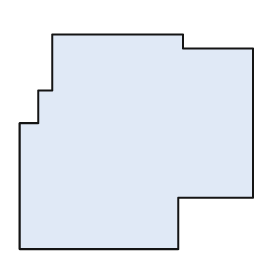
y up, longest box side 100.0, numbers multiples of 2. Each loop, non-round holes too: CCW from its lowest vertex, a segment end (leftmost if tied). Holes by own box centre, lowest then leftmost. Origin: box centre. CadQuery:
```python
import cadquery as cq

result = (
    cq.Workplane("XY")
    .moveTo(-50.0, -46.0)
    .lineTo(18.0, -46.0)
    .lineTo(18.0, -24.0)
    .lineTo(50.0, -24.0)
    .lineTo(50.0, 40.0)
    .lineTo(20.0, 40.0)
    .lineTo(20.0, 46.0)
    .lineTo(-36.0, 46.0)
    .lineTo(-36.0, 22.0)
    .lineTo(-42.0, 22.0)
    .lineTo(-42.0, 8.0)
    .lineTo(-50.0, 8.0)
    .close()
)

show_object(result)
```